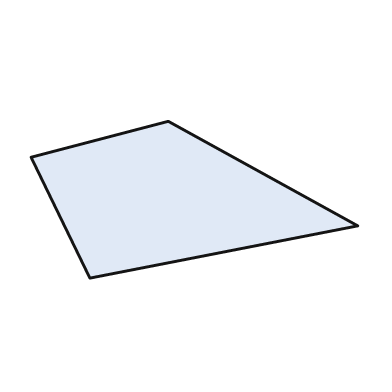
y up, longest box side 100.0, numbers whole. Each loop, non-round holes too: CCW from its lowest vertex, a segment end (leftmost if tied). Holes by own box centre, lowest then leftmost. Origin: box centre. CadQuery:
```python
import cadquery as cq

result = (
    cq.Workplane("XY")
    .moveTo(-32.0, -24.0)
    .lineTo(50.0, -8.0)
    .lineTo(-8.0, 24.0)
    .lineTo(-50.0, 13.0)
    .close()
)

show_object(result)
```